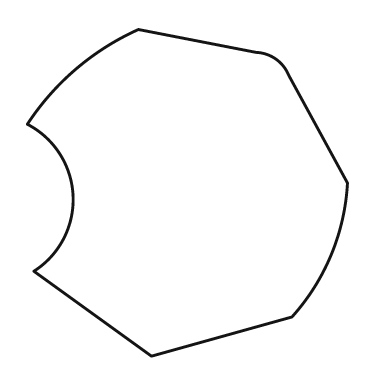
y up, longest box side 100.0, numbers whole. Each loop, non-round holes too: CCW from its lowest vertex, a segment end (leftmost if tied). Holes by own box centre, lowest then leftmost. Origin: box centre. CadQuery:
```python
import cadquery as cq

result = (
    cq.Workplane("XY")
    .moveTo(-11.0, -50.0)
    .lineTo(32.0, -38.0)
    .threePointArc((44.0, -19.0), (49.0, 3.0))
    .lineTo(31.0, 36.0)
    .threePointArc((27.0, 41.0), (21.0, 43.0))
    .lineTo(-15.0, 50.0)
    .threePointArc((-34.0, 38.0), (-49.0, 21.0))
    .threePointArc((-35.0, -1.0), (-47.0, -24.0))
    .close()
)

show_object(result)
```